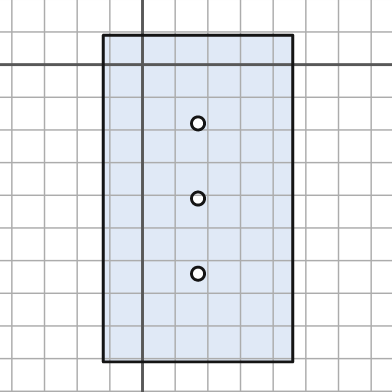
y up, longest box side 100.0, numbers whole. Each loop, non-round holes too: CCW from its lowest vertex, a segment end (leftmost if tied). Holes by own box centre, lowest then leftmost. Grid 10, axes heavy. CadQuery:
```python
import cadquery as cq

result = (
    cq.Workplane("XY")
    .moveTo(-12.0, -91.0)
    .lineTo(46.0, -91.0)
    .lineTo(46.0, 9.0)
    .lineTo(-12.0, 9.0)
    .close()
    .moveTo(17.0, -64.0)
    .circle(2.0)
    .moveTo(17.0, -41.0)
    .circle(2.0)
    .moveTo(17.0, -18.0)
    .circle(2.0)
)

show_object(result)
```